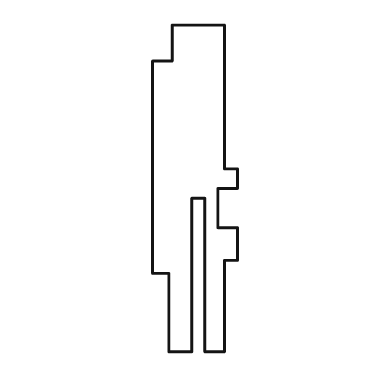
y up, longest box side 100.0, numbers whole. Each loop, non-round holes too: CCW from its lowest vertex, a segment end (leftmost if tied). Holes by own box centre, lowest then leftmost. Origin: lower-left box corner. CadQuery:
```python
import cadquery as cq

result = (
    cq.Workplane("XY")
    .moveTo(5.0, 0.0)
    .lineTo(12.0, 0.0)
    .lineTo(12.0, 47.0)
    .lineTo(16.0, 47.0)
    .lineTo(16.0, 0.0)
    .lineTo(22.0, 0.0)
    .lineTo(22.0, 28.0)
    .lineTo(26.0, 28.0)
    .lineTo(26.0, 38.0)
    .lineTo(20.0, 38.0)
    .lineTo(20.0, 50.0)
    .lineTo(26.0, 50.0)
    .lineTo(26.0, 56.0)
    .lineTo(22.0, 56.0)
    .lineTo(22.0, 100.0)
    .lineTo(6.0, 100.0)
    .lineTo(6.0, 89.0)
    .lineTo(0.0, 89.0)
    .lineTo(0.0, 24.0)
    .lineTo(5.0, 24.0)
    .close()
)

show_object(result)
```